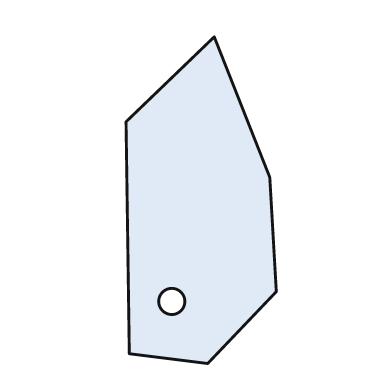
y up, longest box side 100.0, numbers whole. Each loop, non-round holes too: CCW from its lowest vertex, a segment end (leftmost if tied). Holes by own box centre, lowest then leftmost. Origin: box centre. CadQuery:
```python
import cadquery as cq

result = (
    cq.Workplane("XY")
    .moveTo(2.0, -50.0)
    .lineTo(23.0, -28.0)
    .lineTo(21.0, 7.0)
    .lineTo(4.0, 50.0)
    .lineTo(-23.0, 24.0)
    .lineTo(-22.0, -47.0)
    .close()
    .moveTo(-9.0, -31.0)
    .circle(4.0)
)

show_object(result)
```